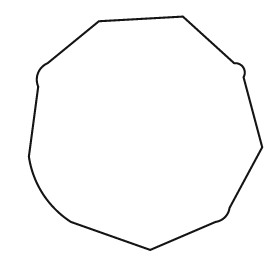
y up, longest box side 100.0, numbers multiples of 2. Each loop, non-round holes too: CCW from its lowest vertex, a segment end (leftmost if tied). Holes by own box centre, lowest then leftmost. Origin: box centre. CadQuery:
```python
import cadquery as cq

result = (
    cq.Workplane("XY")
    .moveTo(2.0, -50.0)
    .lineTo(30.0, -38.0)
    .threePointArc((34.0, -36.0), (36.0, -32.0))
    .lineTo(50.0, -6.0)
    .lineTo(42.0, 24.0)
    .threePointArc((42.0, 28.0), (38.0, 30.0))
    .lineTo(16.0, 50.0)
    .lineTo(-20.0, 48.0)
    .lineTo(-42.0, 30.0)
    .threePointArc((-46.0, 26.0), (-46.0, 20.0))
    .lineTo(-50.0, -10.0)
    .threePointArc((-44.0, -26.0), (-32.0, -38.0))
    .close()
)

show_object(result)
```